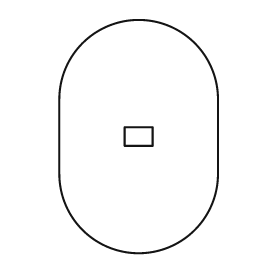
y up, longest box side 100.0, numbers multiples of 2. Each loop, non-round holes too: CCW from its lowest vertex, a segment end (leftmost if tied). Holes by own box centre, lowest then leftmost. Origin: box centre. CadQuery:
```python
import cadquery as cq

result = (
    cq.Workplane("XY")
    .moveTo(-34.0, -16.0)
    .threePointArc((0.0, -50.0), (34.0, -16.0))
    .lineTo(34.0, 16.0)
    .threePointArc((0.0, 50.0), (-34.0, 16.0))
    .close()
    .moveTo(-6.0, -4.0)
    .lineTo(6.0, -4.0)
    .lineTo(6.0, 4.0)
    .lineTo(-6.0, 4.0)
    .close()
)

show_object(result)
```